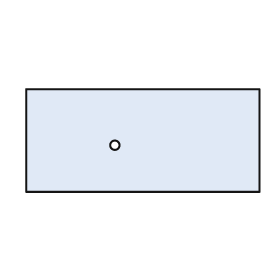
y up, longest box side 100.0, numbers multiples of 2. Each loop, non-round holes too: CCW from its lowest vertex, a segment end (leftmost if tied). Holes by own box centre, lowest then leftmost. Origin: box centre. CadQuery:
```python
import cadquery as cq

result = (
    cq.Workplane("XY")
    .moveTo(-50.0, -22.0)
    .lineTo(50.0, -22.0)
    .lineTo(50.0, 22.0)
    .lineTo(-50.0, 22.0)
    .close()
    .moveTo(-12.0, -2.0)
    .circle(2.0)
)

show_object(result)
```